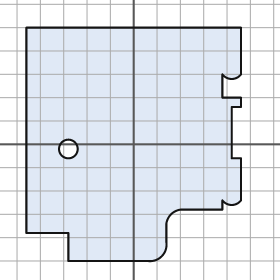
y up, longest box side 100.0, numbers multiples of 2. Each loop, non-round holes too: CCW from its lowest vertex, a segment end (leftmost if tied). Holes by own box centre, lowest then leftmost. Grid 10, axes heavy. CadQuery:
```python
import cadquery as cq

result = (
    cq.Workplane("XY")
    .moveTo(-28.0, -50.0)
    .lineTo(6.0, -50.0)
    .threePointArc((12.0, -48.0), (14.0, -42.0))
    .lineTo(14.0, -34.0)
    .threePointArc((16.0, -30.0), (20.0, -28.0))
    .lineTo(38.0, -28.0)
    .lineTo(38.0, -24.0)
    .threePointArc((42.0, -26.0), (46.0, -24.0))
    .lineTo(46.0, -6.0)
    .lineTo(42.0, -6.0)
    .lineTo(42.0, 16.0)
    .lineTo(46.0, 16.0)
    .lineTo(46.0, 20.0)
    .lineTo(38.0, 20.0)
    .lineTo(38.0, 30.0)
    .threePointArc((42.0, 28.0), (46.0, 30.0))
    .lineTo(46.0, 50.0)
    .lineTo(-46.0, 50.0)
    .lineTo(-46.0, -38.0)
    .lineTo(-28.0, -38.0)
    .close()
    .moveTo(-28.0, -2.0)
    .circle(4.0)
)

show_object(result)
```